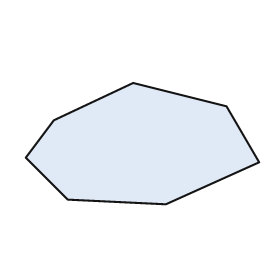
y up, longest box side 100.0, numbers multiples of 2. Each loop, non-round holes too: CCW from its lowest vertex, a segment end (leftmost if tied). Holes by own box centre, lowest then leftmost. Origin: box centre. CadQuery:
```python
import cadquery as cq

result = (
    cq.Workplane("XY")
    .moveTo(10.0, -26.0)
    .lineTo(50.0, -8.0)
    .lineTo(36.0, 16.0)
    .lineTo(-4.0, 26.0)
    .lineTo(-38.0, 10.0)
    .lineTo(-50.0, -6.0)
    .lineTo(-32.0, -24.0)
    .close()
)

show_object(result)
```